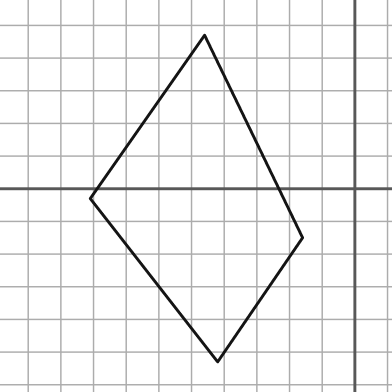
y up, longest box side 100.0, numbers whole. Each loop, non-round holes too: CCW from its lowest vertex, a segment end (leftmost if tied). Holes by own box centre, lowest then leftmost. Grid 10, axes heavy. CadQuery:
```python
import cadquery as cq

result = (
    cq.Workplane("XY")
    .moveTo(-42.0, -53.0)
    .lineTo(-16.0, -15.0)
    .lineTo(-46.0, 47.0)
    .lineTo(-81.0, -3.0)
    .close()
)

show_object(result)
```